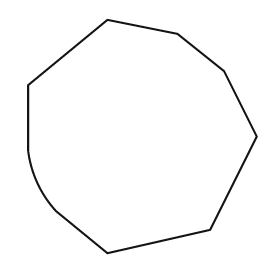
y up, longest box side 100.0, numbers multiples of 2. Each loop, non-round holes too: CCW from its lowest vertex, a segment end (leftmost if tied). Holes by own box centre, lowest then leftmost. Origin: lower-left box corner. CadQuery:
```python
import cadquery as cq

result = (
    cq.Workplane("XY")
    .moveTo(34.0, 0.0)
    .lineTo(78.0, 10.0)
    .lineTo(98.0, 50.0)
    .lineTo(84.0, 78.0)
    .lineTo(64.0, 94.0)
    .lineTo(34.0, 100.0)
    .lineTo(0.0, 72.0)
    .lineTo(0.0, 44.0)
    .threePointArc((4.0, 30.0), (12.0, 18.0))
    .close()
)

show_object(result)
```